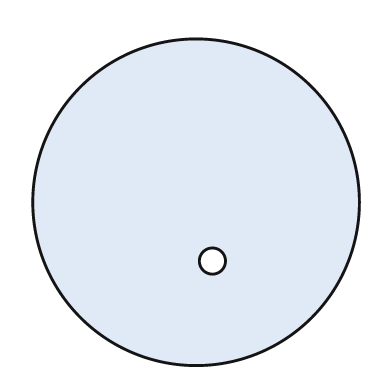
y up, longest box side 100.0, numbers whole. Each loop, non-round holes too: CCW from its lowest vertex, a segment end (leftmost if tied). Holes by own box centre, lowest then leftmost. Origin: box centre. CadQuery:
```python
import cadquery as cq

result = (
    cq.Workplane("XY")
    .moveTo(0.0, 0.0)
    .circle(50.0)
    .moveTo(5.0, -18.0)
    .circle(4.0)
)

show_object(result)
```